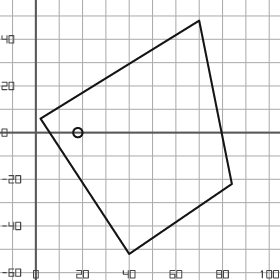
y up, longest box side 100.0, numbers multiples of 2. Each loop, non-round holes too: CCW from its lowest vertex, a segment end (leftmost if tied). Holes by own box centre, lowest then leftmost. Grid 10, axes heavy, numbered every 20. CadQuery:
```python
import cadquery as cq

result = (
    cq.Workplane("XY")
    .moveTo(40.0, -52.0)
    .lineTo(84.0, -22.0)
    .lineTo(70.0, 48.0)
    .lineTo(2.0, 6.0)
    .close()
    .moveTo(18.0, 0.0)
    .circle(2.0)
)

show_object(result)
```